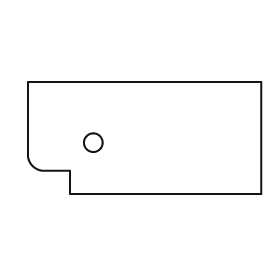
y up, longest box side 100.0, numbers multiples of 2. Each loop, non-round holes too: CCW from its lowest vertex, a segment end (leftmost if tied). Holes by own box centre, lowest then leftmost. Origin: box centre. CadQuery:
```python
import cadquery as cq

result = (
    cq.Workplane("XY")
    .moveTo(-32.0, -24.0)
    .lineTo(50.0, -24.0)
    .lineTo(50.0, 24.0)
    .lineTo(-50.0, 24.0)
    .lineTo(-50.0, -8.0)
    .threePointArc((-48.0, -12.0), (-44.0, -14.0))
    .lineTo(-32.0, -14.0)
    .close()
    .moveTo(-22.0, -2.0)
    .circle(4.0)
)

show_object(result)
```